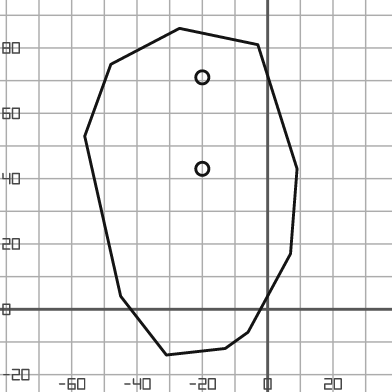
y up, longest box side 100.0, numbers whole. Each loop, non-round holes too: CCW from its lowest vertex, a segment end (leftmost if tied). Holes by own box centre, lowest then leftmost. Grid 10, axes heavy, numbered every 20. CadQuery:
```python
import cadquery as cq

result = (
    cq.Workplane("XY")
    .moveTo(-31.0, -14.0)
    .lineTo(-13.0, -12.0)
    .lineTo(-6.0, -7.0)
    .lineTo(7.0, 17.0)
    .lineTo(9.0, 43.0)
    .lineTo(-3.0, 81.0)
    .lineTo(-27.0, 86.0)
    .lineTo(-48.0, 75.0)
    .lineTo(-56.0, 53.0)
    .lineTo(-45.0, 4.0)
    .close()
    .moveTo(-20.0, 43.0)
    .circle(2.0)
    .moveTo(-20.0, 71.0)
    .circle(2.0)
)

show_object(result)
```